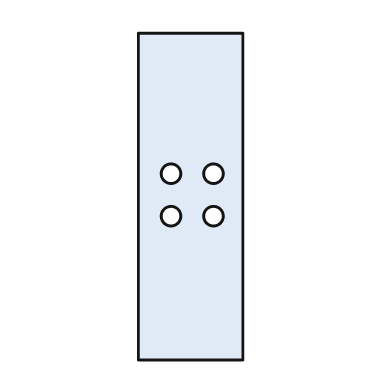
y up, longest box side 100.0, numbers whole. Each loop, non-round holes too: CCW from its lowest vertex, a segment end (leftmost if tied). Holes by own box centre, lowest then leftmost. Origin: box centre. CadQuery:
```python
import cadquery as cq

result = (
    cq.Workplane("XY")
    .moveTo(-16.0, -50.0)
    .lineTo(16.0, -50.0)
    .lineTo(16.0, 50.0)
    .lineTo(-16.0, 50.0)
    .close()
    .moveTo(-6.0, -6.0)
    .circle(3.0)
    .moveTo(7.0, -6.0)
    .circle(3.0)
    .moveTo(-6.0, 7.0)
    .circle(3.0)
    .moveTo(7.0, 7.0)
    .circle(3.0)
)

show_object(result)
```